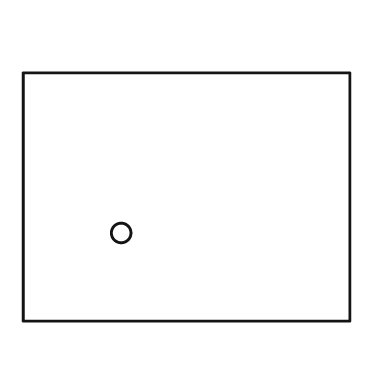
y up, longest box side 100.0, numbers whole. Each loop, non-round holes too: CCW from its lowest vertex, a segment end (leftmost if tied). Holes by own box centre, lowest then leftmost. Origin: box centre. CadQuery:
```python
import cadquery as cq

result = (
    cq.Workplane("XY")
    .moveTo(-50.0, -38.0)
    .lineTo(50.0, -38.0)
    .lineTo(50.0, 38.0)
    .lineTo(-50.0, 38.0)
    .close()
    .moveTo(-20.0, -11.0)
    .circle(3.0)
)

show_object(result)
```